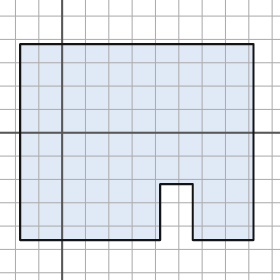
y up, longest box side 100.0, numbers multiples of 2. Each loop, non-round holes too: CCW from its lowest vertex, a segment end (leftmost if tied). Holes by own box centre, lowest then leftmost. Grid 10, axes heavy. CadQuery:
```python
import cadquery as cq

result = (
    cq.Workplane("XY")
    .moveTo(-18.0, -46.0)
    .lineTo(42.0, -46.0)
    .lineTo(42.0, -22.0)
    .lineTo(56.0, -22.0)
    .lineTo(56.0, -46.0)
    .lineTo(82.0, -46.0)
    .lineTo(82.0, 38.0)
    .lineTo(-18.0, 38.0)
    .close()
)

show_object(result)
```